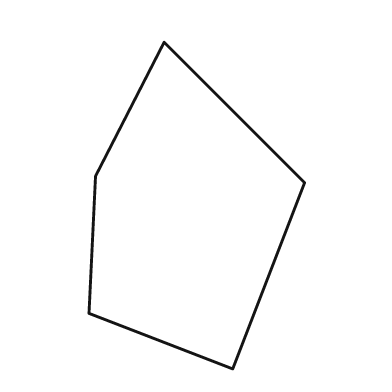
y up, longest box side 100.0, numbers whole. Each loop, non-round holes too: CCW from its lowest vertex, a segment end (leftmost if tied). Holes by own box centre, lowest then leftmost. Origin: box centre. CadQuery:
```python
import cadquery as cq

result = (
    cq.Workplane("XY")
    .moveTo(11.0, -50.0)
    .lineTo(33.0, 7.0)
    .lineTo(-10.0, 50.0)
    .lineTo(-31.0, 9.0)
    .lineTo(-33.0, -33.0)
    .close()
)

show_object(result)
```